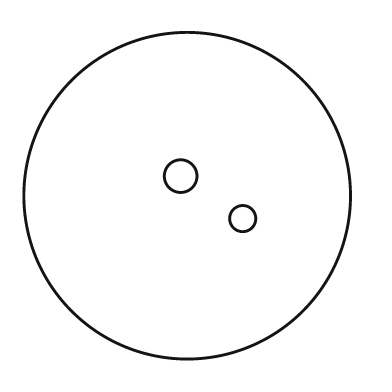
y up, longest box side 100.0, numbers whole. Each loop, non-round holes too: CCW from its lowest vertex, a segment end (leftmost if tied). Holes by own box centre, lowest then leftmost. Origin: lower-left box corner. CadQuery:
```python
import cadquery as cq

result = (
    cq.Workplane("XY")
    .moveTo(50.0, 50.0)
    .circle(50.0)
    .moveTo(67.0, 43.0)
    .circle(4.0)
    .moveTo(48.0, 56.0)
    .circle(5.0)
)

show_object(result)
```